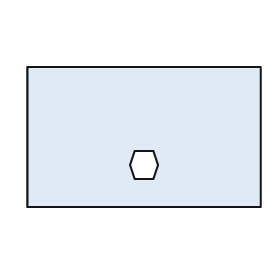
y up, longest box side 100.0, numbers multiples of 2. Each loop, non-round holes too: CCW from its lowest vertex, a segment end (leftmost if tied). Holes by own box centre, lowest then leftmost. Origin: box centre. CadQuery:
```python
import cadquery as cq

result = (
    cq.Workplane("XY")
    .moveTo(-50.0, -30.0)
    .lineTo(50.0, -30.0)
    .lineTo(50.0, 30.0)
    .lineTo(-50.0, 30.0)
    .close()
    .moveTo(-4.0, -18.0)
    .lineTo(4.0, -18.0)
    .lineTo(6.0, -12.0)
    .lineTo(4.0, -6.0)
    .lineTo(-4.0, -6.0)
    .lineTo(-6.0, -12.0)
    .close()
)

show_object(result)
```